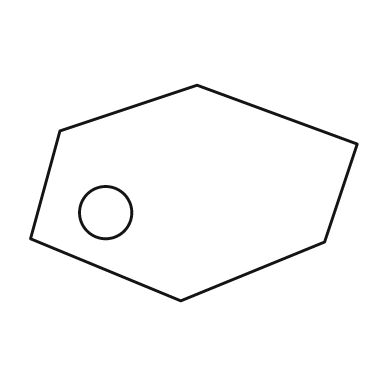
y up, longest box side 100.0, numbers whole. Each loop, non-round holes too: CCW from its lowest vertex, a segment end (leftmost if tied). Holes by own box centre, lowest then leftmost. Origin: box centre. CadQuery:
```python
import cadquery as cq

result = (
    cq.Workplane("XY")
    .moveTo(-4.0, -33.0)
    .lineTo(40.0, -15.0)
    .lineTo(50.0, 15.0)
    .lineTo(1.0, 33.0)
    .lineTo(-41.0, 19.0)
    .lineTo(-50.0, -14.0)
    .close()
    .moveTo(-27.0, -6.0)
    .circle(8.0)
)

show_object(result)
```